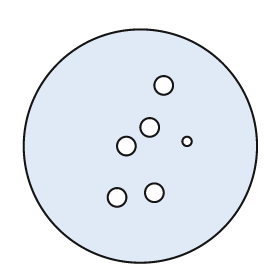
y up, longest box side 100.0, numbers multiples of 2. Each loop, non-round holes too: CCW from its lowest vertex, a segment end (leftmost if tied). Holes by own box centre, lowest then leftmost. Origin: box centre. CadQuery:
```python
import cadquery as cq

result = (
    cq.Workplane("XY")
    .moveTo(0.0, 0.0)
    .circle(50.0)
    .moveTo(-10.0, -22.0)
    .circle(4.0)
    .moveTo(6.0, -20.0)
    .circle(4.0)
    .moveTo(-6.0, 0.0)
    .circle(4.0)
    .moveTo(20.0, 2.0)
    .circle(2.0)
    .moveTo(4.0, 8.0)
    .circle(4.0)
    .moveTo(10.0, 26.0)
    .circle(4.0)
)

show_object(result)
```